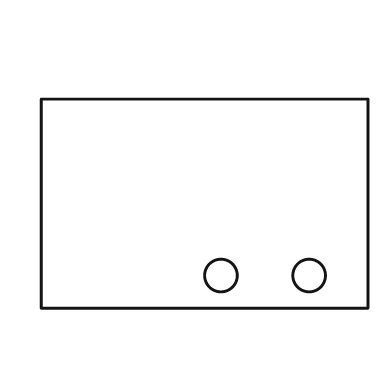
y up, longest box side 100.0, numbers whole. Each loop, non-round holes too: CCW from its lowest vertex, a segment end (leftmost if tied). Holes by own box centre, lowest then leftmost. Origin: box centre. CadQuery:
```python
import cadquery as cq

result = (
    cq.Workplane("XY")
    .moveTo(-50.0, -32.0)
    .lineTo(50.0, -32.0)
    .lineTo(50.0, 32.0)
    .lineTo(-50.0, 32.0)
    .close()
    .moveTo(5.0, -22.0)
    .circle(5.0)
    .moveTo(32.0, -22.0)
    .circle(5.0)
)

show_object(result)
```